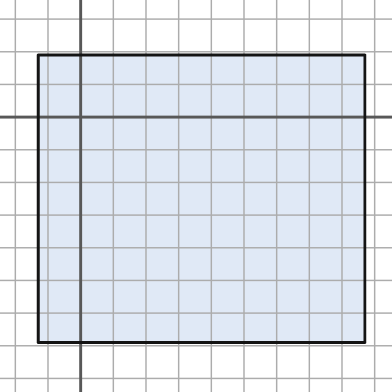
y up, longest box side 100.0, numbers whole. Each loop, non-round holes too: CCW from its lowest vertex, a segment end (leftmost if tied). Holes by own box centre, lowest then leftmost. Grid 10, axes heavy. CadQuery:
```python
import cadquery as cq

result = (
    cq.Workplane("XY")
    .moveTo(-13.0, -69.0)
    .lineTo(87.0, -69.0)
    .lineTo(87.0, 19.0)
    .lineTo(-13.0, 19.0)
    .close()
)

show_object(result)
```